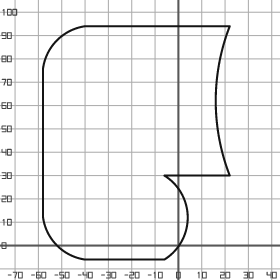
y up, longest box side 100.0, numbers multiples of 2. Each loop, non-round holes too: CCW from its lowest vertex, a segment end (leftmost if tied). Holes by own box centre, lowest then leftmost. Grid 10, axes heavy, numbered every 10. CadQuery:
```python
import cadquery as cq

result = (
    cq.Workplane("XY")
    .moveTo(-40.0, -6.0)
    .lineTo(-6.0, -6.0)
    .threePointArc((4.0, 12.0), (-6.0, 30.0))
    .lineTo(22.0, 30.0)
    .threePointArc((16.0, 62.0), (22.0, 94.0))
    .lineTo(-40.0, 94.0)
    .threePointArc((-52.0, 88.0), (-58.0, 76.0))
    .lineTo(-58.0, 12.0)
    .threePointArc((-52.0, 0.0), (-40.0, -6.0))
    .close()
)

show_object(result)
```